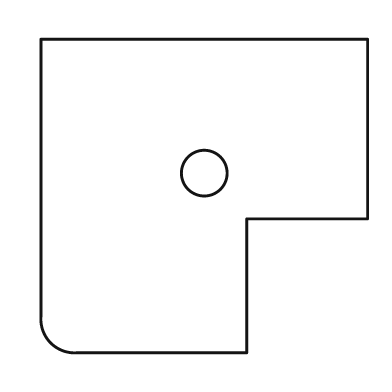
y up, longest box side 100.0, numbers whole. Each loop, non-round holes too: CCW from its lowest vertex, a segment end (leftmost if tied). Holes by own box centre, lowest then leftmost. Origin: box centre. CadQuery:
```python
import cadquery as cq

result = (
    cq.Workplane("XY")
    .moveTo(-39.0, -48.0)
    .lineTo(13.0, -48.0)
    .lineTo(13.0, -7.0)
    .lineTo(50.0, -7.0)
    .lineTo(50.0, 48.0)
    .lineTo(-50.0, 48.0)
    .lineTo(-50.0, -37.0)
    .threePointArc((-47.0, -45.0), (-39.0, -48.0))
    .close()
    .moveTo(0.0, 7.0)
    .circle(7.0)
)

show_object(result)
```